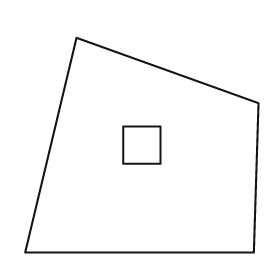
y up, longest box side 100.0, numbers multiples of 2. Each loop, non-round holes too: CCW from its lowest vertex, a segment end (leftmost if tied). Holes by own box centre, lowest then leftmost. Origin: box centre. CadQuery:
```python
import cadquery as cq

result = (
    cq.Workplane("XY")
    .moveTo(-50.0, -46.0)
    .lineTo(48.0, -46.0)
    .lineTo(50.0, 18.0)
    .lineTo(-28.0, 46.0)
    .close()
    .moveTo(-8.0, -8.0)
    .lineTo(8.0, -8.0)
    .lineTo(8.0, 8.0)
    .lineTo(-8.0, 8.0)
    .close()
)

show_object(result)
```